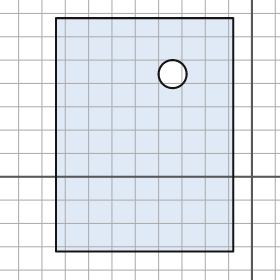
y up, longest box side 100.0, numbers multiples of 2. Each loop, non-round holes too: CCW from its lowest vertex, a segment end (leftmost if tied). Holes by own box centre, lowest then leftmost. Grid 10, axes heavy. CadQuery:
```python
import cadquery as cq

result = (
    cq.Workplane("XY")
    .moveTo(-84.0, -32.0)
    .lineTo(-8.0, -32.0)
    .lineTo(-8.0, 68.0)
    .lineTo(-84.0, 68.0)
    .close()
    .moveTo(-34.0, 44.0)
    .circle(6.0)
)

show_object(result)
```